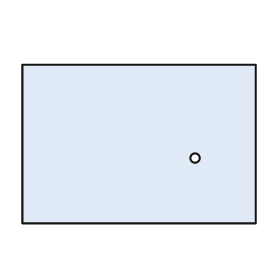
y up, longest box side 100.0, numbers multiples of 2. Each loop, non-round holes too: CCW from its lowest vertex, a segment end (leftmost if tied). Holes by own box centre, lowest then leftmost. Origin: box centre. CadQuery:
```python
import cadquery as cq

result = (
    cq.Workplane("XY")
    .moveTo(-50.0, -34.0)
    .lineTo(50.0, -34.0)
    .lineTo(50.0, 34.0)
    .lineTo(-50.0, 34.0)
    .close()
    .moveTo(24.0, -6.0)
    .circle(2.0)
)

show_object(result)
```